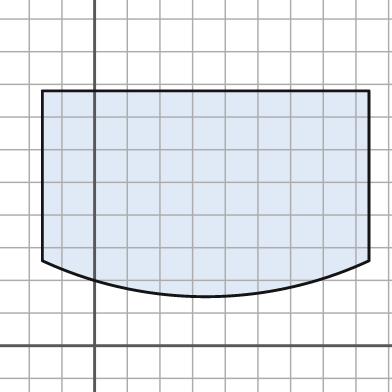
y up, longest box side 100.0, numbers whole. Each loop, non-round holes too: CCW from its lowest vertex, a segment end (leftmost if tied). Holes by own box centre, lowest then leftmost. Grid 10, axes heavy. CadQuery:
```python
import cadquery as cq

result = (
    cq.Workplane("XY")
    .moveTo(-16.0, 26.0)
    .threePointArc((34.0, 15.0), (84.0, 26.0))
    .lineTo(84.0, 78.0)
    .lineTo(-16.0, 78.0)
    .close()
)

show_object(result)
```